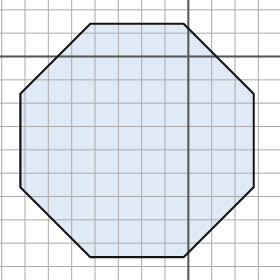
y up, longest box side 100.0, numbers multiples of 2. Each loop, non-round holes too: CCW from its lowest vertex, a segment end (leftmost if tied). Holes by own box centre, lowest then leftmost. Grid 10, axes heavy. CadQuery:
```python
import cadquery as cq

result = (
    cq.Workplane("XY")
    .moveTo(-42.0, -86.0)
    .lineTo(-2.0, -86.0)
    .lineTo(28.0, -56.0)
    .lineTo(28.0, -16.0)
    .lineTo(-2.0, 14.0)
    .lineTo(-42.0, 14.0)
    .lineTo(-72.0, -16.0)
    .lineTo(-72.0, -56.0)
    .close()
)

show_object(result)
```